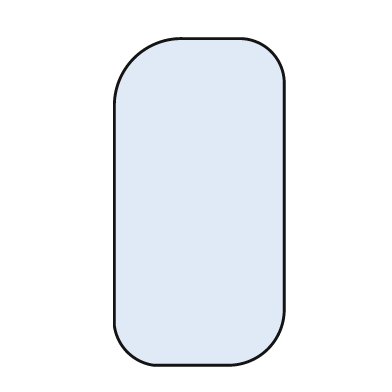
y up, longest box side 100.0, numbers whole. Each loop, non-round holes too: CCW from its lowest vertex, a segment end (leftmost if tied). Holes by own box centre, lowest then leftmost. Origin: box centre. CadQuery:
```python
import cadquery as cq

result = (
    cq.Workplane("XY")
    .moveTo(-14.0, -50.0)
    .lineTo(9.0, -50.0)
    .threePointArc((21.0, -45.0), (26.0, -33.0))
    .lineTo(26.0, 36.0)
    .threePointArc((22.0, 46.0), (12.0, 50.0))
    .lineTo(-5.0, 50.0)
    .threePointArc((-20.0, 44.0), (-26.0, 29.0))
    .lineTo(-26.0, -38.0)
    .threePointArc((-22.0, -46.0), (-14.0, -50.0))
    .close()
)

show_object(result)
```